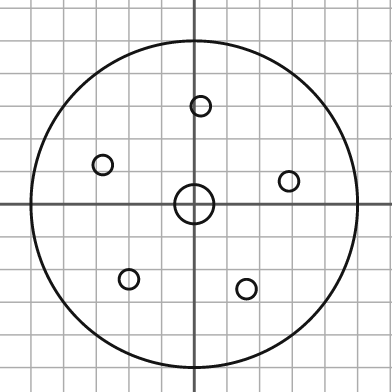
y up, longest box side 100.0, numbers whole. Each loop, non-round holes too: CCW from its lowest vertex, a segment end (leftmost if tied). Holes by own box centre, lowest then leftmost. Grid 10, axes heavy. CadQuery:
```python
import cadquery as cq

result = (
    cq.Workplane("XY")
    .moveTo(0.0, 0.0)
    .circle(50.0)
    .moveTo(16.0, -26.0)
    .circle(3.0)
    .moveTo(-20.0, -23.0)
    .circle(3.0)
    .moveTo(0.0, 0.0)
    .circle(6.0)
    .moveTo(29.0, 7.0)
    .circle(3.0)
    .moveTo(-28.0, 12.0)
    .circle(3.0)
    .moveTo(2.0, 30.0)
    .circle(3.0)
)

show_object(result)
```